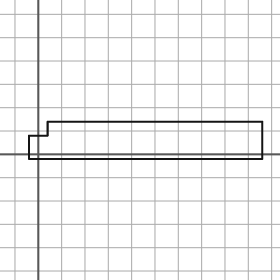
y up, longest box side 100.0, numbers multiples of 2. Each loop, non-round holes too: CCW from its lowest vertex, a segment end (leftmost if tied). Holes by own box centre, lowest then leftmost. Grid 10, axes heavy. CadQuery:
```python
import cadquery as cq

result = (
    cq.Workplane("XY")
    .moveTo(-4.0, -2.0)
    .lineTo(96.0, -2.0)
    .lineTo(96.0, 14.0)
    .lineTo(4.0, 14.0)
    .lineTo(4.0, 8.0)
    .lineTo(-4.0, 8.0)
    .close()
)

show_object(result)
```